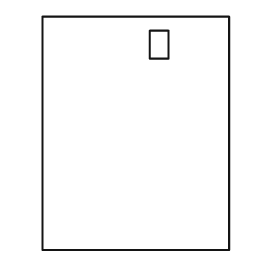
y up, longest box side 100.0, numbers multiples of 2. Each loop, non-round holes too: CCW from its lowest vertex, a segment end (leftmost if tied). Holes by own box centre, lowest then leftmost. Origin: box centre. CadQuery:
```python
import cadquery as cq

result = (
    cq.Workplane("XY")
    .moveTo(-40.0, -50.0)
    .lineTo(40.0, -50.0)
    .lineTo(40.0, 50.0)
    .lineTo(-40.0, 50.0)
    .close()
    .moveTo(6.0, 32.0)
    .lineTo(14.0, 32.0)
    .lineTo(14.0, 44.0)
    .lineTo(6.0, 44.0)
    .close()
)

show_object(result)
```